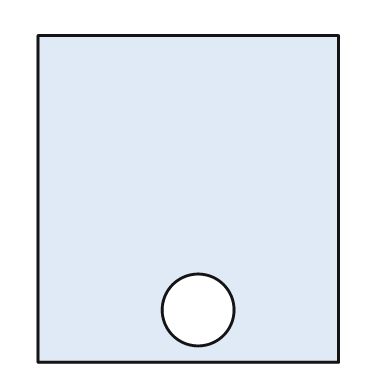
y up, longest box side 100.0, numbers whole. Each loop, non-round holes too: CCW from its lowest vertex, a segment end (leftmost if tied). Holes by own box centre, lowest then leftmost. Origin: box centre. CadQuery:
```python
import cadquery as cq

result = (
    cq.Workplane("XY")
    .moveTo(-46.0, -50.0)
    .lineTo(46.0, -50.0)
    .lineTo(46.0, 50.0)
    .lineTo(-46.0, 50.0)
    .close()
    .moveTo(3.0, -34.0)
    .circle(11.0)
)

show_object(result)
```